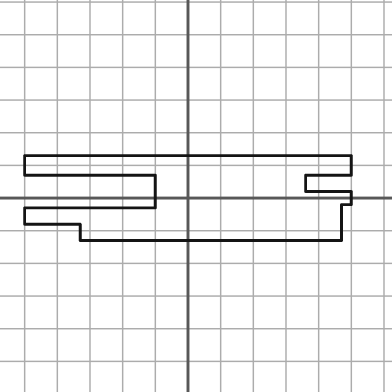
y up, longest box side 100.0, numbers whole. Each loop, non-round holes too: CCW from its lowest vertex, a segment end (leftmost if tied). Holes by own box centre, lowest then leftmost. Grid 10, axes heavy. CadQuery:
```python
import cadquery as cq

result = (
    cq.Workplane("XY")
    .moveTo(-33.0, -13.0)
    .lineTo(47.0, -13.0)
    .lineTo(47.0, -2.0)
    .lineTo(50.0, -2.0)
    .lineTo(50.0, 2.0)
    .lineTo(36.0, 2.0)
    .lineTo(36.0, 7.0)
    .lineTo(50.0, 7.0)
    .lineTo(50.0, 13.0)
    .lineTo(-50.0, 13.0)
    .lineTo(-50.0, 7.0)
    .lineTo(-10.0, 7.0)
    .lineTo(-10.0, -3.0)
    .lineTo(-50.0, -3.0)
    .lineTo(-50.0, -8.0)
    .lineTo(-33.0, -8.0)
    .close()
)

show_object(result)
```